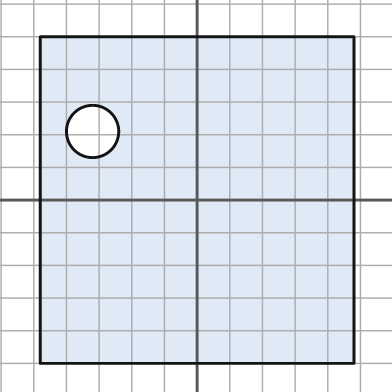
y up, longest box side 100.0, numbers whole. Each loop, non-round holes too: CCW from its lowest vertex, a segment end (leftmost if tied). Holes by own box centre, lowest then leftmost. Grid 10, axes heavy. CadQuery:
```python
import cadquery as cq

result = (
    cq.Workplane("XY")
    .moveTo(-48.0, -50.0)
    .lineTo(48.0, -50.0)
    .lineTo(48.0, 50.0)
    .lineTo(-48.0, 50.0)
    .close()
    .moveTo(-32.0, 21.0)
    .circle(8.0)
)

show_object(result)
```